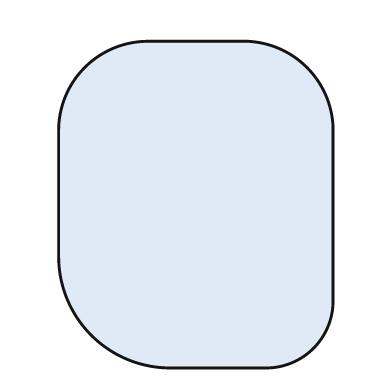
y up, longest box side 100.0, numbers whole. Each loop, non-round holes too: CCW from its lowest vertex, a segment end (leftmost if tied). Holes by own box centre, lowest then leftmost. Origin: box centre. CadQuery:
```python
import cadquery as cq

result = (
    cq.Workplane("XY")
    .moveTo(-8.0, -50.0)
    .lineTo(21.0, -50.0)
    .threePointArc((36.0, -44.0), (42.0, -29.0))
    .lineTo(42.0, 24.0)
    .threePointArc((34.0, 42.0), (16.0, 50.0))
    .lineTo(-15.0, 50.0)
    .threePointArc((-34.0, 42.0), (-42.0, 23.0))
    .lineTo(-42.0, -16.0)
    .threePointArc((-32.0, -40.0), (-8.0, -50.0))
    .close()
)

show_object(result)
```